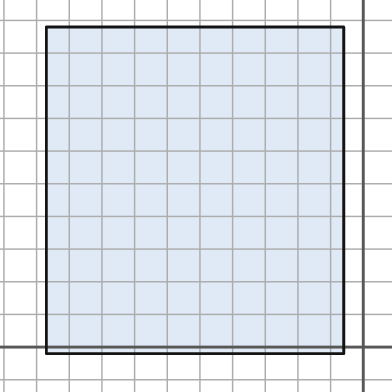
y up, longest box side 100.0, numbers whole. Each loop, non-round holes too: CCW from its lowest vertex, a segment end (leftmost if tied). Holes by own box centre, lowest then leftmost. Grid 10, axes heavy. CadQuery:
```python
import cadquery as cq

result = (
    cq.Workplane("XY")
    .moveTo(-97.0, -2.0)
    .lineTo(-6.0, -2.0)
    .lineTo(-6.0, 98.0)
    .lineTo(-97.0, 98.0)
    .close()
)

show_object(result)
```